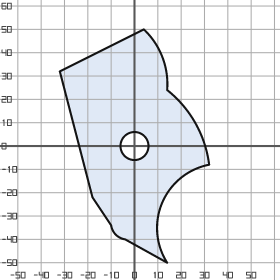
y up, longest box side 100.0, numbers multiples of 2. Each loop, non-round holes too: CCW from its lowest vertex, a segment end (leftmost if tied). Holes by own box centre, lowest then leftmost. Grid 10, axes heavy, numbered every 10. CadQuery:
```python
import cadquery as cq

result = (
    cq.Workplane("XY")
    .moveTo(14.0, -50.0)
    .threePointArc((12.0, -24.0), (32.0, -8.0))
    .threePointArc((26.0, 10.0), (14.0, 24.0))
    .threePointArc((12.0, 38.0), (4.0, 50.0))
    .lineTo(-32.0, 32.0)
    .lineTo(-18.0, -22.0)
    .lineTo(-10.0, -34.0)
    .threePointArc((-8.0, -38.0), (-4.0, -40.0))
    .close()
    .moveTo(0.0, 0.0)
    .circle(6.0)
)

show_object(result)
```